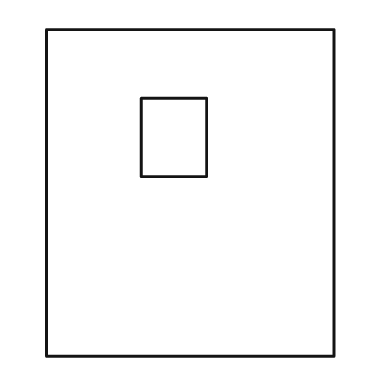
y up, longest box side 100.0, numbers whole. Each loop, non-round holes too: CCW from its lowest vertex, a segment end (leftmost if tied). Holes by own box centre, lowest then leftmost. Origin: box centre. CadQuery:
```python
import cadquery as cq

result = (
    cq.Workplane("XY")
    .moveTo(-44.0, -50.0)
    .lineTo(44.0, -50.0)
    .lineTo(44.0, 50.0)
    .lineTo(-44.0, 50.0)
    .close()
    .moveTo(-15.0, 5.0)
    .lineTo(5.0, 5.0)
    .lineTo(5.0, 29.0)
    .lineTo(-15.0, 29.0)
    .close()
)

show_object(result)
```